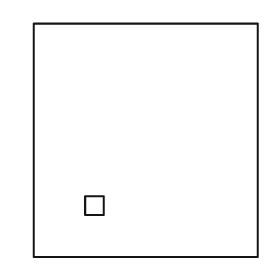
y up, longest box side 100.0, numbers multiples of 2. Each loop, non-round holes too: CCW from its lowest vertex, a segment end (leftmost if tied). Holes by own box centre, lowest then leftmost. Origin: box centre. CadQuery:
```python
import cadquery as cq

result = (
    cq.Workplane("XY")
    .moveTo(-48.0, -50.0)
    .lineTo(48.0, -50.0)
    .lineTo(48.0, 50.0)
    .lineTo(-48.0, 50.0)
    .close()
    .moveTo(-26.0, -32.0)
    .lineTo(-18.0, -32.0)
    .lineTo(-18.0, -24.0)
    .lineTo(-26.0, -24.0)
    .close()
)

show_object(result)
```